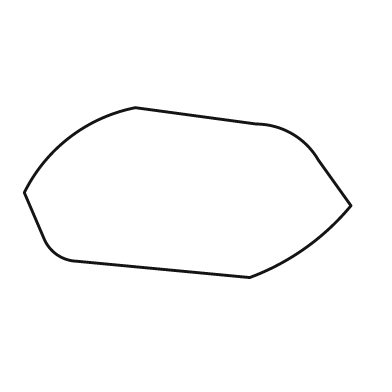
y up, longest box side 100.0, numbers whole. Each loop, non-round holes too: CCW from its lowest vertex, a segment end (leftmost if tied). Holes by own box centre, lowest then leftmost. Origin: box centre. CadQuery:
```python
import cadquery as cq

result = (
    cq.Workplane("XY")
    .moveTo(19.0, -26.0)
    .threePointArc((36.0, -17.0), (50.0, -4.0))
    .lineTo(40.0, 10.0)
    .threePointArc((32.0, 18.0), (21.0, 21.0))
    .lineTo(-16.0, 26.0)
    .threePointArc((-36.0, 17.0), (-50.0, 0.0))
    .lineTo(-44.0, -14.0)
    .threePointArc((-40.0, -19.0), (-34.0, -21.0))
    .close()
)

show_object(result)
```